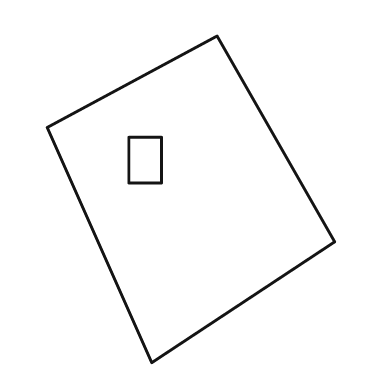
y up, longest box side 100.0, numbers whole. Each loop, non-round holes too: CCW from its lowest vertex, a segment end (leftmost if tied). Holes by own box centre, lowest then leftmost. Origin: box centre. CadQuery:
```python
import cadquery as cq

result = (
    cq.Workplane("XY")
    .moveTo(-12.0, -50.0)
    .lineTo(44.0, -13.0)
    .lineTo(8.0, 50.0)
    .lineTo(-44.0, 22.0)
    .close()
    .moveTo(-19.0, 5.0)
    .lineTo(-9.0, 5.0)
    .lineTo(-9.0, 19.0)
    .lineTo(-19.0, 19.0)
    .close()
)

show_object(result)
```